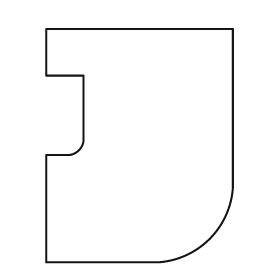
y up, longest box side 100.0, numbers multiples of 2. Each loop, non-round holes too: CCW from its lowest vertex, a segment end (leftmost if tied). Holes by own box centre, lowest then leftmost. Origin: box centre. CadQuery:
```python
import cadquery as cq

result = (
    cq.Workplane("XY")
    .moveTo(-40.0, -50.0)
    .lineTo(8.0, -50.0)
    .threePointArc((30.0, -40.0), (40.0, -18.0))
    .lineTo(40.0, 50.0)
    .lineTo(-40.0, 50.0)
    .lineTo(-40.0, 30.0)
    .lineTo(-24.0, 30.0)
    .lineTo(-24.0, 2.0)
    .threePointArc((-26.0, -2.0), (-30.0, -4.0))
    .lineTo(-40.0, -4.0)
    .close()
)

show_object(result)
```